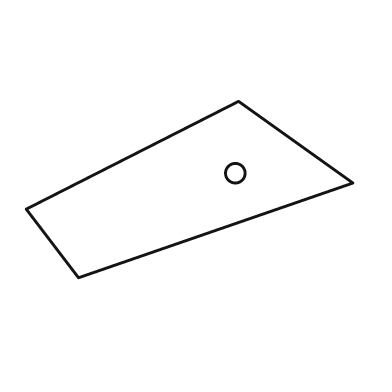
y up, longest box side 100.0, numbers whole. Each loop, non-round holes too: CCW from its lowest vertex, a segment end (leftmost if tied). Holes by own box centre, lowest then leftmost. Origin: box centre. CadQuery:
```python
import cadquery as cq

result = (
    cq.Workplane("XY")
    .moveTo(-34.0, -27.0)
    .lineTo(50.0, 2.0)
    .lineTo(15.0, 27.0)
    .lineTo(-50.0, -6.0)
    .close()
    .moveTo(14.0, 5.0)
    .circle(3.0)
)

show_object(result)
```